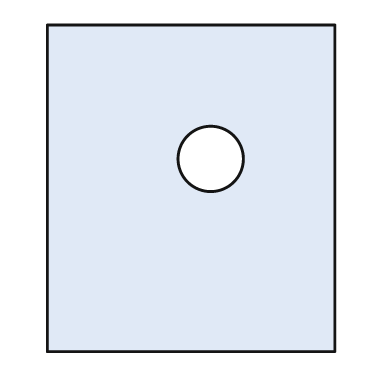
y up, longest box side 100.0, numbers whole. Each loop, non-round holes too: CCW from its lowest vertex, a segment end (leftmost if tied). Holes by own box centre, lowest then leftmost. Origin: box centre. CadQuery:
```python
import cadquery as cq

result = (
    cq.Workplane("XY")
    .moveTo(-44.0, -50.0)
    .lineTo(44.0, -50.0)
    .lineTo(44.0, 50.0)
    .lineTo(-44.0, 50.0)
    .close()
    .moveTo(6.0, 9.0)
    .circle(10.0)
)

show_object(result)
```